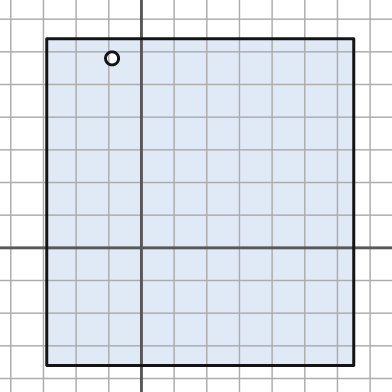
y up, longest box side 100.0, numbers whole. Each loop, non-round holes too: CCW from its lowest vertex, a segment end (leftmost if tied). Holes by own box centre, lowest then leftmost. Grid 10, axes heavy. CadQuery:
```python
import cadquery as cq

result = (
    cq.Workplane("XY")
    .moveTo(-29.0, -36.0)
    .lineTo(65.0, -36.0)
    .lineTo(65.0, 64.0)
    .lineTo(-29.0, 64.0)
    .close()
    .moveTo(-9.0, 58.0)
    .circle(2.0)
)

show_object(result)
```